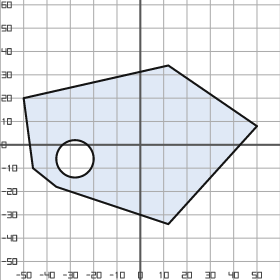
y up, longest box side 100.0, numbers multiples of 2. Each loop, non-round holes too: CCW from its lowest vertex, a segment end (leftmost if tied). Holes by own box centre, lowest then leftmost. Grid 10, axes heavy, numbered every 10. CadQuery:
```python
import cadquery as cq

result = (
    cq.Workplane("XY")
    .moveTo(12.0, -34.0)
    .lineTo(50.0, 8.0)
    .lineTo(12.0, 34.0)
    .lineTo(-50.0, 20.0)
    .lineTo(-46.0, -10.0)
    .lineTo(-36.0, -18.0)
    .close()
    .moveTo(-28.0, -6.0)
    .circle(8.0)
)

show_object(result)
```